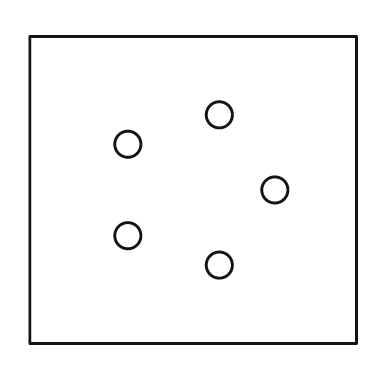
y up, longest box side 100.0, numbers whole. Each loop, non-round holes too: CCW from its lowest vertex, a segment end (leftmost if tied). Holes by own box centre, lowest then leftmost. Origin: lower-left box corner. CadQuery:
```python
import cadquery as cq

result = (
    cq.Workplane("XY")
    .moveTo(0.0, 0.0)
    .lineTo(100.0, 0.0)
    .lineTo(100.0, 94.0)
    .lineTo(0.0, 94.0)
    .close()
    .moveTo(58.0, 24.0)
    .circle(4.0)
    .moveTo(30.0, 33.0)
    .circle(4.0)
    .moveTo(75.0, 47.0)
    .circle(4.0)
    .moveTo(30.0, 61.0)
    .circle(4.0)
    .moveTo(58.0, 70.0)
    .circle(4.0)
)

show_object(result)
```